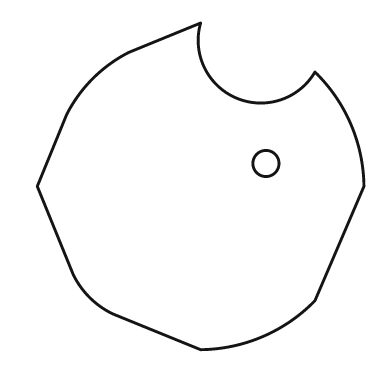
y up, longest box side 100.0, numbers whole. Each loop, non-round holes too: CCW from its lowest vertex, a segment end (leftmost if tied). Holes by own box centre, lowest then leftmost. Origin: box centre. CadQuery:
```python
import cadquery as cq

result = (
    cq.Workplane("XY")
    .moveTo(0.0, -50.0)
    .threePointArc((19.0, -46.0), (35.0, -35.0))
    .lineTo(50.0, 0.0)
    .threePointArc((46.0, 19.0), (35.0, 35.0))
    .threePointArc((11.0, 27.0), (0.0, 50.0))
    .lineTo(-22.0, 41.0)
    .threePointArc((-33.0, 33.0), (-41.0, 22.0))
    .lineTo(-50.0, 0.0)
    .lineTo(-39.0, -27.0)
    .threePointArc((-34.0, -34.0), (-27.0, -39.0))
    .close()
    .moveTo(20.0, 7.0)
    .circle(4.0)
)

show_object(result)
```